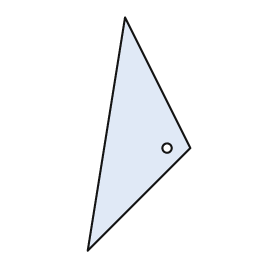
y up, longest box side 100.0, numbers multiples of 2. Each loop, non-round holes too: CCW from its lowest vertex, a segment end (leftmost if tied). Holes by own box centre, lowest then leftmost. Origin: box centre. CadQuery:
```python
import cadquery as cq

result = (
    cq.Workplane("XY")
    .moveTo(-22.0, -50.0)
    .lineTo(22.0, -6.0)
    .lineTo(-6.0, 50.0)
    .close()
    .moveTo(12.0, -6.0)
    .circle(2.0)
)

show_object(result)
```